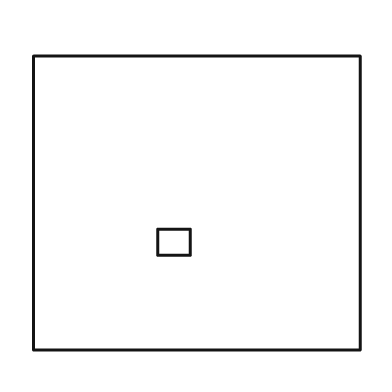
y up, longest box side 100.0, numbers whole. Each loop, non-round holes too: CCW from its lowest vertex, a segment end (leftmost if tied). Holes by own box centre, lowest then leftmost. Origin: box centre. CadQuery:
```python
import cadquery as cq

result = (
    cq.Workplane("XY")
    .moveTo(-50.0, -45.0)
    .lineTo(50.0, -45.0)
    .lineTo(50.0, 45.0)
    .lineTo(-50.0, 45.0)
    .close()
    .moveTo(-12.0, -16.0)
    .lineTo(-2.0, -16.0)
    .lineTo(-2.0, -8.0)
    .lineTo(-12.0, -8.0)
    .close()
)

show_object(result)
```